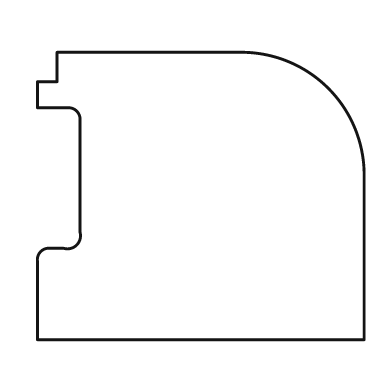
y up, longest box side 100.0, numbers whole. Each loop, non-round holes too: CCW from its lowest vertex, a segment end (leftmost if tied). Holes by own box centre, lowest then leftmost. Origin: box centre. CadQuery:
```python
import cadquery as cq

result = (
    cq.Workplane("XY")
    .moveTo(-50.0, -44.0)
    .lineTo(50.0, -44.0)
    .lineTo(50.0, 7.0)
    .threePointArc((39.0, 33.0), (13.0, 44.0))
    .lineTo(-44.0, 44.0)
    .lineTo(-44.0, 35.0)
    .lineTo(-50.0, 35.0)
    .lineTo(-50.0, 27.0)
    .lineTo(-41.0, 27.0)
    .threePointArc((-38.0, 26.0), (-37.0, 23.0))
    .lineTo(-37.0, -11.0)
    .threePointArc((-38.0, -15.0), (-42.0, -16.0))
    .lineTo(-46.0, -16.0)
    .threePointArc((-49.0, -17.0), (-50.0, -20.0))
    .close()
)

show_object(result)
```